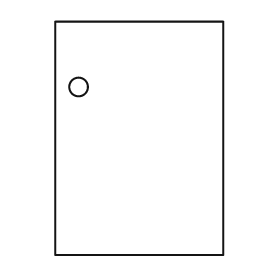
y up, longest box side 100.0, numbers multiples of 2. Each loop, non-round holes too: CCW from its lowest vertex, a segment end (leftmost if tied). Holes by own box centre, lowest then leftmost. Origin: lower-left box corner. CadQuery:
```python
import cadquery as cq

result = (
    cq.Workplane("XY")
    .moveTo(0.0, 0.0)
    .lineTo(72.0, 0.0)
    .lineTo(72.0, 100.0)
    .lineTo(0.0, 100.0)
    .close()
    .moveTo(10.0, 72.0)
    .circle(4.0)
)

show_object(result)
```